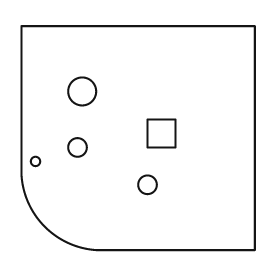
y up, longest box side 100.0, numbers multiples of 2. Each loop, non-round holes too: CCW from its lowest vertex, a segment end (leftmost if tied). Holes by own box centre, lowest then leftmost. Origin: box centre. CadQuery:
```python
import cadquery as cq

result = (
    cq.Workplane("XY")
    .moveTo(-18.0, -48.0)
    .lineTo(50.0, -48.0)
    .lineTo(50.0, 48.0)
    .lineTo(-50.0, 48.0)
    .lineTo(-50.0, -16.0)
    .threePointArc((-40.0, -38.0), (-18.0, -48.0))
    .close()
    .moveTo(4.0, -20.0)
    .circle(4.0)
    .moveTo(-44.0, -10.0)
    .circle(2.0)
    .moveTo(-26.0, -4.0)
    .circle(4.0)
    .moveTo(4.0, -4.0)
    .lineTo(16.0, -4.0)
    .lineTo(16.0, 8.0)
    .lineTo(4.0, 8.0)
    .close()
    .moveTo(-24.0, 20.0)
    .circle(6.0)
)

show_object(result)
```